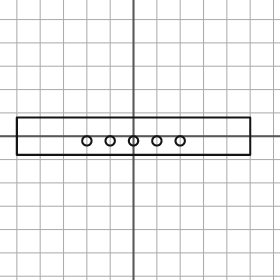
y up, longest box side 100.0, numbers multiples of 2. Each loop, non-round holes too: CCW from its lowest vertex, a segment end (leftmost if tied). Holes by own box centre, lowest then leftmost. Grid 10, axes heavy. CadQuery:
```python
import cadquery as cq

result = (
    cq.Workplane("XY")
    .moveTo(-50.0, -8.0)
    .lineTo(50.0, -8.0)
    .lineTo(50.0, 8.0)
    .lineTo(-50.0, 8.0)
    .close()
    .moveTo(-20.0, -2.0)
    .circle(2.0)
    .moveTo(-10.0, -2.0)
    .circle(2.0)
    .moveTo(0.0, -2.0)
    .circle(2.0)
    .moveTo(10.0, -2.0)
    .circle(2.0)
    .moveTo(20.0, -2.0)
    .circle(2.0)
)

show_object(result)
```